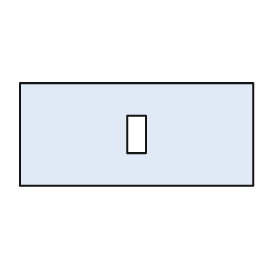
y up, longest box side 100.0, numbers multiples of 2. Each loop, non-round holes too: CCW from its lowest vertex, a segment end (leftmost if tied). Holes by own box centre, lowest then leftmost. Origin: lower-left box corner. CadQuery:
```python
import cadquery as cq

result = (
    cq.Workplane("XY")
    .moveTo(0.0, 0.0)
    .lineTo(100.0, 0.0)
    .lineTo(100.0, 44.0)
    .lineTo(0.0, 44.0)
    .close()
    .moveTo(46.0, 14.0)
    .lineTo(54.0, 14.0)
    .lineTo(54.0, 30.0)
    .lineTo(46.0, 30.0)
    .close()
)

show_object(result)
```